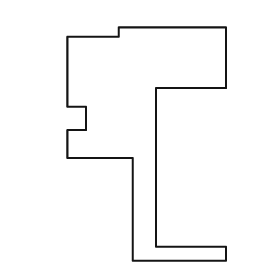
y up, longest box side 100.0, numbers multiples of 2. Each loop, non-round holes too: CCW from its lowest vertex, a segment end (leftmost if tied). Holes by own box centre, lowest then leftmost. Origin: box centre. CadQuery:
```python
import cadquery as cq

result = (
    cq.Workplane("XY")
    .moveTo(-6.0, -50.0)
    .lineTo(34.0, -50.0)
    .lineTo(34.0, -44.0)
    .lineTo(4.0, -44.0)
    .lineTo(4.0, 24.0)
    .lineTo(34.0, 24.0)
    .lineTo(34.0, 50.0)
    .lineTo(-12.0, 50.0)
    .lineTo(-12.0, 46.0)
    .lineTo(-34.0, 46.0)
    .lineTo(-34.0, 16.0)
    .lineTo(-26.0, 16.0)
    .lineTo(-26.0, 6.0)
    .lineTo(-34.0, 6.0)
    .lineTo(-34.0, -6.0)
    .lineTo(-6.0, -6.0)
    .close()
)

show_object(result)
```